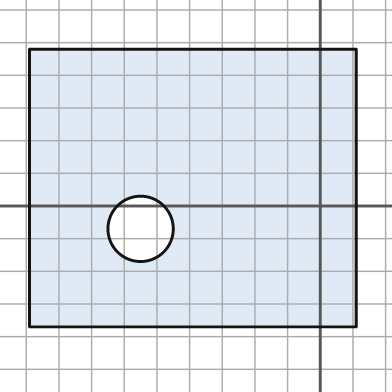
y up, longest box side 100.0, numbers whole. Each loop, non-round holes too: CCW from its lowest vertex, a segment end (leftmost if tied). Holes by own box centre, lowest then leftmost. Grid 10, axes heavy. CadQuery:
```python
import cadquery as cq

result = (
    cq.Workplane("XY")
    .moveTo(-89.0, -37.0)
    .lineTo(11.0, -37.0)
    .lineTo(11.0, 48.0)
    .lineTo(-89.0, 48.0)
    .close()
    .moveTo(-55.0, -7.0)
    .circle(10.0)
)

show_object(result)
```